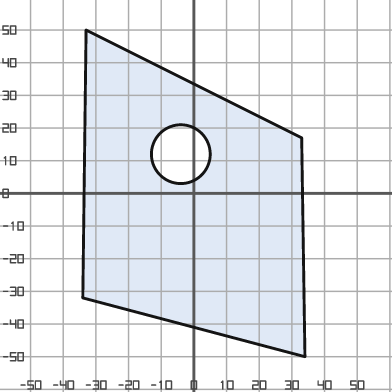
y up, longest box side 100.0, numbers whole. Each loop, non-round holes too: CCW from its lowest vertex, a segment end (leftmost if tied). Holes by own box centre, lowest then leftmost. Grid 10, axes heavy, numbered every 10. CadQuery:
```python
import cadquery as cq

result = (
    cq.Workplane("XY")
    .moveTo(34.0, -50.0)
    .lineTo(33.0, 17.0)
    .lineTo(-33.0, 50.0)
    .lineTo(-34.0, -32.0)
    .close()
    .moveTo(-4.0, 12.0)
    .circle(9.0)
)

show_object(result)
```